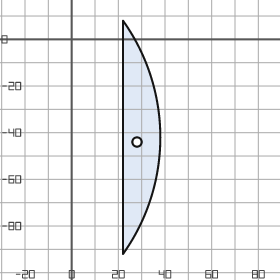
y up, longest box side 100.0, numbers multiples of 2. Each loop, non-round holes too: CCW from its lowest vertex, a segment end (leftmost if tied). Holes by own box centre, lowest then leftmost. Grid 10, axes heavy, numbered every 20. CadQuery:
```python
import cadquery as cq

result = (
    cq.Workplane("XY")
    .moveTo(22.0, -92.0)
    .threePointArc((38.0, -42.0), (22.0, 8.0))
    .close()
    .moveTo(28.0, -44.0)
    .circle(2.0)
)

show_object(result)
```